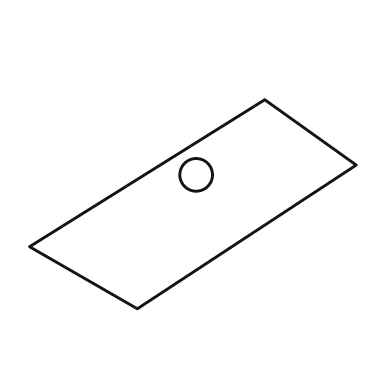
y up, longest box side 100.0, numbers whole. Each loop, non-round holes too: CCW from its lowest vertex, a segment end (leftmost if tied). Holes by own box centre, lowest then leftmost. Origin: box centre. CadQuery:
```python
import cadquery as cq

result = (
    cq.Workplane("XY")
    .moveTo(-17.0, -32.0)
    .lineTo(50.0, 12.0)
    .lineTo(22.0, 32.0)
    .lineTo(-50.0, -13.0)
    .close()
    .moveTo(1.0, 9.0)
    .circle(5.0)
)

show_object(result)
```